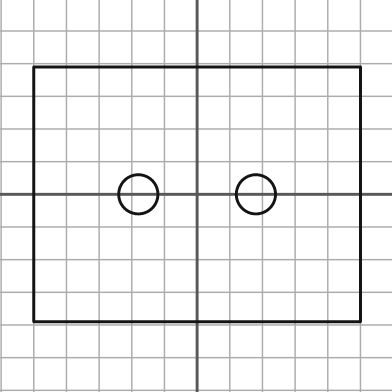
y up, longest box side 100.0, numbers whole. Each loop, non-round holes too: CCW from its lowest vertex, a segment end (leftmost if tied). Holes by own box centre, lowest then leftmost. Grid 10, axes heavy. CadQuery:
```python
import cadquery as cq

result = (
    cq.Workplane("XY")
    .moveTo(-50.0, -39.0)
    .lineTo(50.0, -39.0)
    .lineTo(50.0, 39.0)
    .lineTo(-50.0, 39.0)
    .close()
    .moveTo(-18.0, 0.0)
    .circle(6.0)
    .moveTo(18.0, 0.0)
    .circle(6.0)
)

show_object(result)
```